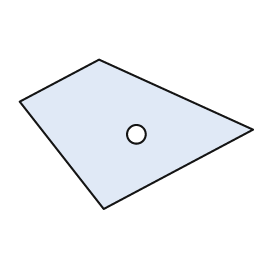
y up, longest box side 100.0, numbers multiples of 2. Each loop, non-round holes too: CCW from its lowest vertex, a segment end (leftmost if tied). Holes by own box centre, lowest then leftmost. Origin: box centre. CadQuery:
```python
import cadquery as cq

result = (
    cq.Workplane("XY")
    .moveTo(-14.0, -32.0)
    .lineTo(50.0, 2.0)
    .lineTo(-16.0, 32.0)
    .lineTo(-50.0, 14.0)
    .close()
    .moveTo(0.0, 0.0)
    .circle(4.0)
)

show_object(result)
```